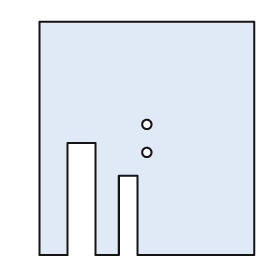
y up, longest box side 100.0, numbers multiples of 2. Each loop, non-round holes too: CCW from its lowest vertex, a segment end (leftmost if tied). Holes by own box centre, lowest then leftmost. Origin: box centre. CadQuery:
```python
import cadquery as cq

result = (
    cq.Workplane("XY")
    .moveTo(-46.0, -50.0)
    .lineTo(-34.0, -50.0)
    .lineTo(-34.0, -2.0)
    .lineTo(-22.0, -2.0)
    .lineTo(-22.0, -50.0)
    .lineTo(-12.0, -50.0)
    .lineTo(-12.0, -16.0)
    .lineTo(-4.0, -16.0)
    .lineTo(-4.0, -50.0)
    .lineTo(46.0, -50.0)
    .lineTo(46.0, 50.0)
    .lineTo(-46.0, 50.0)
    .close()
    .moveTo(0.0, -6.0)
    .circle(2.0)
    .moveTo(0.0, 6.0)
    .circle(2.0)
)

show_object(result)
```